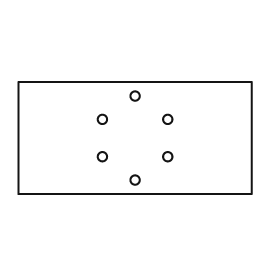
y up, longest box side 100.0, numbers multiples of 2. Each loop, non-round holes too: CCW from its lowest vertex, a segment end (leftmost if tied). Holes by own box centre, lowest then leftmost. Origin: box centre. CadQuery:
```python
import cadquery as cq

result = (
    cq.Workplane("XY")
    .moveTo(-50.0, -24.0)
    .lineTo(50.0, -24.0)
    .lineTo(50.0, 24.0)
    .lineTo(-50.0, 24.0)
    .close()
    .moveTo(0.0, -18.0)
    .circle(2.0)
    .moveTo(-14.0, -8.0)
    .circle(2.0)
    .moveTo(14.0, -8.0)
    .circle(2.0)
    .moveTo(-14.0, 8.0)
    .circle(2.0)
    .moveTo(14.0, 8.0)
    .circle(2.0)
    .moveTo(0.0, 18.0)
    .circle(2.0)
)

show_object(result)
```